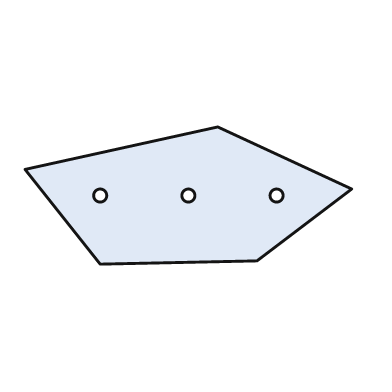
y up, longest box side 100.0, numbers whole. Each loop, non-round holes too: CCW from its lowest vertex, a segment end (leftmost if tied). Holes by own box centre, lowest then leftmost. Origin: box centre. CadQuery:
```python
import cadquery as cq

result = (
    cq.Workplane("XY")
    .moveTo(-27.0, -21.0)
    .lineTo(21.0, -20.0)
    .lineTo(50.0, 2.0)
    .lineTo(9.0, 21.0)
    .lineTo(-50.0, 8.0)
    .close()
    .moveTo(-27.0, 0.0)
    .circle(2.0)
    .moveTo(0.0, 0.0)
    .circle(2.0)
    .moveTo(27.0, 0.0)
    .circle(2.0)
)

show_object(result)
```